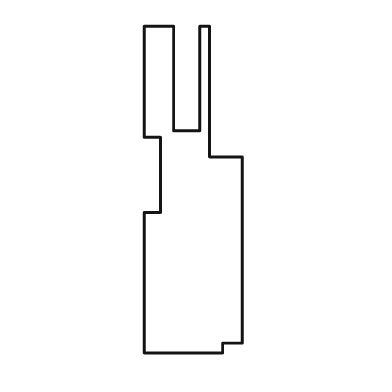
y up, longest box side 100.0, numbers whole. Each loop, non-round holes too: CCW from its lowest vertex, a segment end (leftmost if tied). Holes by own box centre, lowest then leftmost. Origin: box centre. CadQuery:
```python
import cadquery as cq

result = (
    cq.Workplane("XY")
    .moveTo(-15.0, -50.0)
    .lineTo(9.0, -50.0)
    .lineTo(9.0, -47.0)
    .lineTo(15.0, -47.0)
    .lineTo(15.0, 10.0)
    .lineTo(5.0, 10.0)
    .lineTo(5.0, 50.0)
    .lineTo(2.0, 50.0)
    .lineTo(2.0, 18.0)
    .lineTo(-6.0, 18.0)
    .lineTo(-6.0, 50.0)
    .lineTo(-15.0, 50.0)
    .lineTo(-15.0, 16.0)
    .lineTo(-10.0, 16.0)
    .lineTo(-10.0, -7.0)
    .lineTo(-15.0, -7.0)
    .close()
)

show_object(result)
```